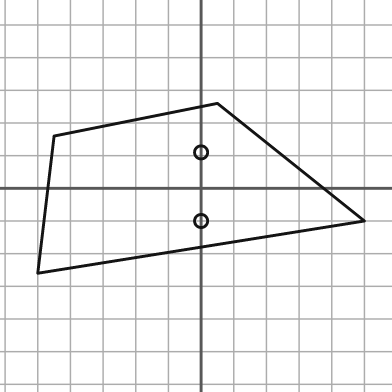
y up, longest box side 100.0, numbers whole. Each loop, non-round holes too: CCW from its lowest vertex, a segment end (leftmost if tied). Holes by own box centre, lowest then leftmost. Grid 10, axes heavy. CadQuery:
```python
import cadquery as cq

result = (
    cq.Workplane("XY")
    .moveTo(-50.0, -26.0)
    .lineTo(50.0, -10.0)
    .lineTo(5.0, 26.0)
    .lineTo(-45.0, 16.0)
    .close()
    .moveTo(0.0, -10.0)
    .circle(2.0)
    .moveTo(0.0, 11.0)
    .circle(2.0)
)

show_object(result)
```